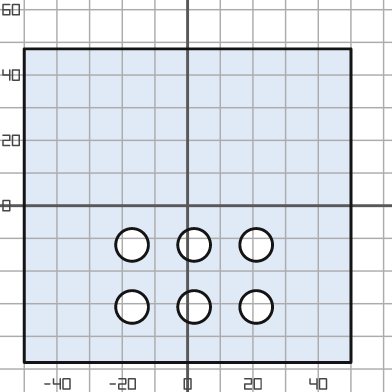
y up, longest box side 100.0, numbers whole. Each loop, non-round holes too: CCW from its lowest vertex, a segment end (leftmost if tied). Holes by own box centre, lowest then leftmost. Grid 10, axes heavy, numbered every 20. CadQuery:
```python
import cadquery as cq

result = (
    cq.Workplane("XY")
    .moveTo(-50.0, -48.0)
    .lineTo(50.0, -48.0)
    .lineTo(50.0, 48.0)
    .lineTo(-50.0, 48.0)
    .close()
    .moveTo(-17.0, -31.0)
    .circle(5.0)
    .moveTo(2.0, -31.0)
    .circle(5.0)
    .moveTo(21.0, -31.0)
    .circle(5.0)
    .moveTo(-17.0, -12.0)
    .circle(5.0)
    .moveTo(2.0, -12.0)
    .circle(5.0)
    .moveTo(21.0, -12.0)
    .circle(5.0)
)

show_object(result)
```